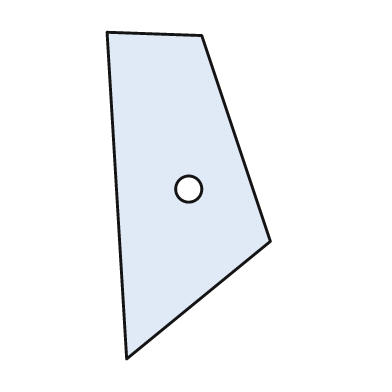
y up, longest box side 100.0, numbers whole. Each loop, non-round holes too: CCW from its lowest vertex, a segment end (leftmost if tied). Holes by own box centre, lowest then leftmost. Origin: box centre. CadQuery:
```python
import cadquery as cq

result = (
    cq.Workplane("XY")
    .moveTo(-19.0, -50.0)
    .lineTo(25.0, -14.0)
    .lineTo(4.0, 49.0)
    .lineTo(-25.0, 50.0)
    .close()
    .moveTo(0.0, 2.0)
    .circle(4.0)
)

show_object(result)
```